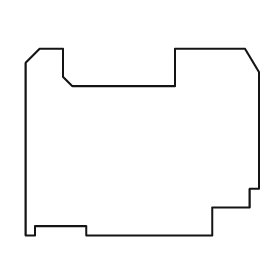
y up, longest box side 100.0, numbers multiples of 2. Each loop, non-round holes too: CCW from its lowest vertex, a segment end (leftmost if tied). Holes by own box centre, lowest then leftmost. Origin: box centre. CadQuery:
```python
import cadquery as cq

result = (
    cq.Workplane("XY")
    .moveTo(-50.0, -40.0)
    .lineTo(-46.0, -40.0)
    .lineTo(-46.0, -36.0)
    .lineTo(-24.0, -36.0)
    .lineTo(-24.0, -40.0)
    .lineTo(30.0, -40.0)
    .lineTo(30.0, -28.0)
    .lineTo(46.0, -28.0)
    .lineTo(46.0, -20.0)
    .lineTo(50.0, -20.0)
    .lineTo(50.0, 30.0)
    .lineTo(44.0, 40.0)
    .lineTo(14.0, 40.0)
    .lineTo(14.0, 24.0)
    .lineTo(-30.0, 24.0)
    .lineTo(-34.0, 28.0)
    .lineTo(-34.0, 40.0)
    .lineTo(-44.0, 40.0)
    .lineTo(-50.0, 34.0)
    .close()
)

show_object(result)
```